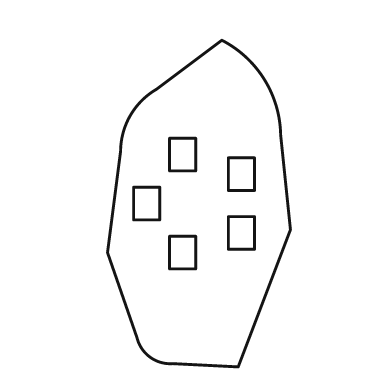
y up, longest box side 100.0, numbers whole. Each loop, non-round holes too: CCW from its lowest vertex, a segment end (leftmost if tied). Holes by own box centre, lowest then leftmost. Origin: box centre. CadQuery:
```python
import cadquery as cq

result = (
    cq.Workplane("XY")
    .moveTo(12.0, -50.0)
    .lineTo(28.0, -8.0)
    .lineTo(25.0, 21.0)
    .threePointArc((20.0, 38.0), (7.0, 50.0))
    .lineTo(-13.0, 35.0)
    .threePointArc((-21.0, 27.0), (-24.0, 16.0))
    .lineTo(-28.0, -15.0)
    .lineTo(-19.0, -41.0)
    .threePointArc((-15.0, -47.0), (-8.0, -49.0))
    .close()
    .moveTo(-9.0, -20.0)
    .lineTo(-1.0, -20.0)
    .lineTo(-1.0, -10.0)
    .lineTo(-9.0, -10.0)
    .close()
    .moveTo(9.0, -14.0)
    .lineTo(17.0, -14.0)
    .lineTo(17.0, -4.0)
    .lineTo(9.0, -4.0)
    .close()
    .moveTo(-20.0, -5.0)
    .lineTo(-12.0, -5.0)
    .lineTo(-12.0, 5.0)
    .lineTo(-20.0, 5.0)
    .close()
    .moveTo(9.0, 4.0)
    .lineTo(17.0, 4.0)
    .lineTo(17.0, 14.0)
    .lineTo(9.0, 14.0)
    .close()
    .moveTo(-9.0, 10.0)
    .lineTo(-1.0, 10.0)
    .lineTo(-1.0, 20.0)
    .lineTo(-9.0, 20.0)
    .close()
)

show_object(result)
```